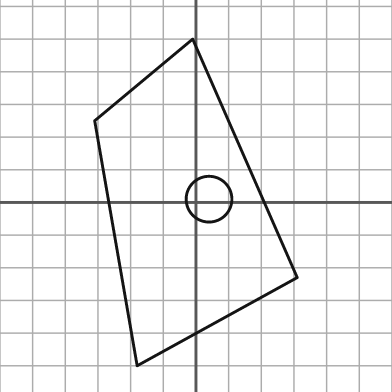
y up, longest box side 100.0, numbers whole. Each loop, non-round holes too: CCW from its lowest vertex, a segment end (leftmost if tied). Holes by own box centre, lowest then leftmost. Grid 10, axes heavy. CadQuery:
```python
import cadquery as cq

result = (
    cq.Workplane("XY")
    .moveTo(-18.0, -50.0)
    .lineTo(31.0, -23.0)
    .lineTo(-1.0, 50.0)
    .lineTo(-31.0, 25.0)
    .close()
    .moveTo(4.0, 1.0)
    .circle(7.0)
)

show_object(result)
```